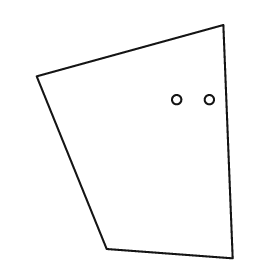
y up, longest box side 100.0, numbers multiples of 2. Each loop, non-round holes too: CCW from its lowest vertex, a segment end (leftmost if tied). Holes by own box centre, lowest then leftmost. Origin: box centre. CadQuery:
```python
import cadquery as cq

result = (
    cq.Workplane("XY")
    .moveTo(42.0, -50.0)
    .lineTo(38.0, 50.0)
    .lineTo(-42.0, 28.0)
    .lineTo(-12.0, -46.0)
    .close()
    .moveTo(18.0, 18.0)
    .circle(2.0)
    .moveTo(32.0, 18.0)
    .circle(2.0)
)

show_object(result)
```